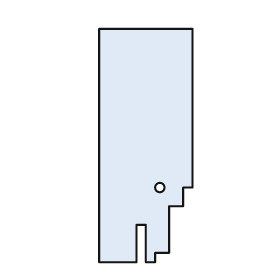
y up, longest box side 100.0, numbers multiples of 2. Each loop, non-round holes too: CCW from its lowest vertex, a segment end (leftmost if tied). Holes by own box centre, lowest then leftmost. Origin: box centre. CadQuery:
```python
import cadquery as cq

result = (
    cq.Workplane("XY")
    .moveTo(-20.0, -50.0)
    .lineTo(-4.0, -50.0)
    .lineTo(-4.0, -34.0)
    .lineTo(0.0, -34.0)
    .lineTo(0.0, -50.0)
    .lineTo(4.0, -50.0)
    .lineTo(4.0, -46.0)
    .lineTo(10.0, -46.0)
    .lineTo(10.0, -26.0)
    .lineTo(16.0, -26.0)
    .lineTo(16.0, -18.0)
    .lineTo(20.0, -18.0)
    .lineTo(20.0, 50.0)
    .lineTo(-20.0, 50.0)
    .close()
    .moveTo(6.0, -18.0)
    .circle(2.0)
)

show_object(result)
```